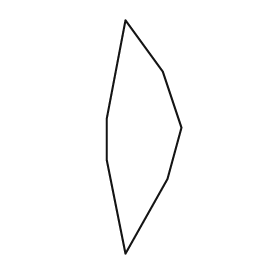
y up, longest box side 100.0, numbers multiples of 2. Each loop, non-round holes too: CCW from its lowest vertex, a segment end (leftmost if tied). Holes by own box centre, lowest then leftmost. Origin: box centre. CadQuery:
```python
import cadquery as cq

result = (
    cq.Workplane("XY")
    .moveTo(-8.0, -50.0)
    .lineTo(10.0, -18.0)
    .lineTo(16.0, 4.0)
    .lineTo(8.0, 28.0)
    .lineTo(-8.0, 50.0)
    .lineTo(-16.0, 8.0)
    .lineTo(-16.0, -10.0)
    .close()
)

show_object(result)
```